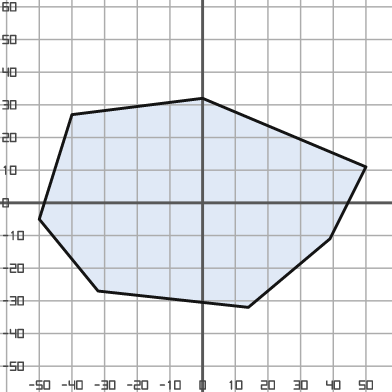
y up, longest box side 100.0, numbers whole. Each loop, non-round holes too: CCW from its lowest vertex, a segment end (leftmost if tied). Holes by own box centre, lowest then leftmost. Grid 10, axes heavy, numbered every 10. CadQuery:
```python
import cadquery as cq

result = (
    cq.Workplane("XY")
    .moveTo(14.0, -32.0)
    .lineTo(39.0, -11.0)
    .lineTo(50.0, 11.0)
    .lineTo(0.0, 32.0)
    .lineTo(-40.0, 27.0)
    .lineTo(-50.0, -5.0)
    .lineTo(-32.0, -27.0)
    .close()
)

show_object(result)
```